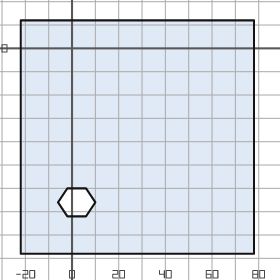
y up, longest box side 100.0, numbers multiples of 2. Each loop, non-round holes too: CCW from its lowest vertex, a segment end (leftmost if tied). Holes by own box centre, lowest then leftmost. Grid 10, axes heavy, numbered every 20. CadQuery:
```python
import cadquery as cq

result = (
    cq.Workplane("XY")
    .moveTo(-22.0, -88.0)
    .lineTo(78.0, -88.0)
    .lineTo(78.0, 12.0)
    .lineTo(-22.0, 12.0)
    .close()
    .moveTo(-2.0, -72.0)
    .lineTo(6.0, -72.0)
    .lineTo(10.0, -66.0)
    .lineTo(6.0, -60.0)
    .lineTo(-2.0, -60.0)
    .lineTo(-6.0, -66.0)
    .close()
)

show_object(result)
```